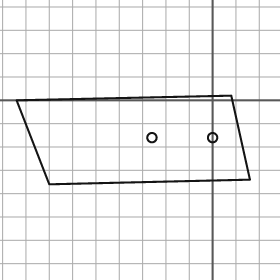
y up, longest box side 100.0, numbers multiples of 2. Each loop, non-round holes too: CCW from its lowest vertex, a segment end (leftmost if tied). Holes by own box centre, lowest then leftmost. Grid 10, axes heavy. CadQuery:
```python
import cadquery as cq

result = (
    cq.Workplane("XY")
    .moveTo(-70.0, -36.0)
    .lineTo(16.0, -34.0)
    .lineTo(8.0, 2.0)
    .lineTo(-84.0, 0.0)
    .close()
    .moveTo(-26.0, -16.0)
    .circle(2.0)
    .moveTo(0.0, -16.0)
    .circle(2.0)
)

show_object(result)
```